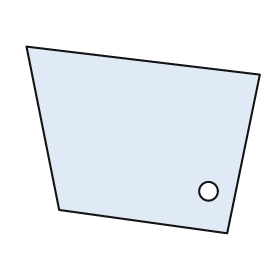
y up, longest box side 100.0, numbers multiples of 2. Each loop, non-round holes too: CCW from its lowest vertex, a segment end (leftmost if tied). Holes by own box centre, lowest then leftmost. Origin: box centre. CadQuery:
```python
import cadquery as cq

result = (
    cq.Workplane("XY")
    .moveTo(36.0, -40.0)
    .lineTo(50.0, 28.0)
    .lineTo(-50.0, 40.0)
    .lineTo(-36.0, -30.0)
    .close()
    .moveTo(28.0, -22.0)
    .circle(4.0)
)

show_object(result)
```